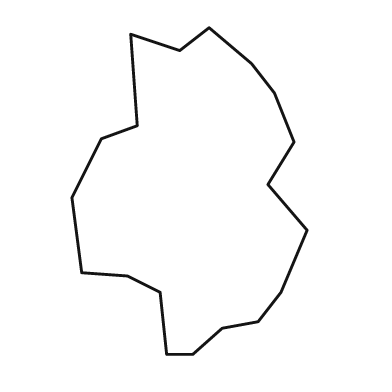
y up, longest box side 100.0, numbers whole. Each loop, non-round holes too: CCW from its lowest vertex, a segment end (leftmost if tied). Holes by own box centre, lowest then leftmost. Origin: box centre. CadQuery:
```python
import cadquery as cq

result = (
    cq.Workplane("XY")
    .moveTo(-7.0, -50.0)
    .lineTo(1.0, -50.0)
    .lineTo(10.0, -42.0)
    .lineTo(21.0, -40.0)
    .lineTo(28.0, -31.0)
    .lineTo(36.0, -12.0)
    .lineTo(24.0, 2.0)
    .lineTo(32.0, 15.0)
    .lineTo(26.0, 30.0)
    .lineTo(19.0, 39.0)
    .lineTo(6.0, 50.0)
    .lineTo(-3.0, 43.0)
    .lineTo(-18.0, 48.0)
    .lineTo(-16.0, 20.0)
    .lineTo(-27.0, 16.0)
    .lineTo(-36.0, -2.0)
    .lineTo(-33.0, -25.0)
    .lineTo(-19.0, -26.0)
    .lineTo(-9.0, -31.0)
    .close()
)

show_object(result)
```